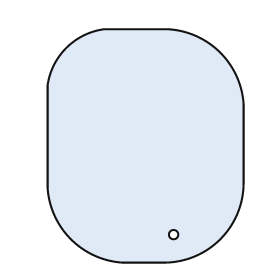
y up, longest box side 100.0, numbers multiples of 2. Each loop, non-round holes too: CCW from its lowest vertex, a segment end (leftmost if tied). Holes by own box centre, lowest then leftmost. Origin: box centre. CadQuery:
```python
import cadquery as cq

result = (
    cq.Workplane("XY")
    .moveTo(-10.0, -50.0)
    .lineTo(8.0, -50.0)
    .threePointArc((32.0, -40.0), (42.0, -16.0))
    .lineTo(42.0, 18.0)
    .threePointArc((32.0, 40.0), (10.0, 50.0))
    .lineTo(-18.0, 50.0)
    .threePointArc((-34.0, 42.0), (-42.0, 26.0))
    .lineTo(-42.0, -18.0)
    .threePointArc((-32.0, -40.0), (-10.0, -50.0))
    .close()
    .moveTo(12.0, -38.0)
    .circle(2.0)
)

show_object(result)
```